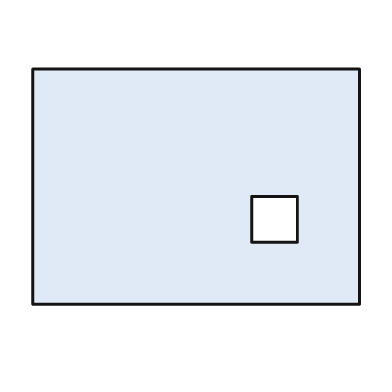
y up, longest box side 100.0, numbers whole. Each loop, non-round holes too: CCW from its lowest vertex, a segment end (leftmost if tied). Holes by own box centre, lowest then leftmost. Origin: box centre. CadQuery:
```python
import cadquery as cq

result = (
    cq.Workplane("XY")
    .moveTo(-50.0, -36.0)
    .lineTo(50.0, -36.0)
    .lineTo(50.0, 36.0)
    .lineTo(-50.0, 36.0)
    .close()
    .moveTo(17.0, -17.0)
    .lineTo(31.0, -17.0)
    .lineTo(31.0, -3.0)
    .lineTo(17.0, -3.0)
    .close()
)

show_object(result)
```